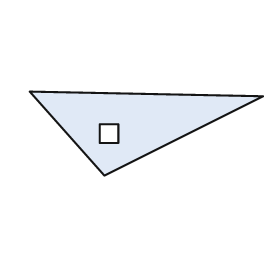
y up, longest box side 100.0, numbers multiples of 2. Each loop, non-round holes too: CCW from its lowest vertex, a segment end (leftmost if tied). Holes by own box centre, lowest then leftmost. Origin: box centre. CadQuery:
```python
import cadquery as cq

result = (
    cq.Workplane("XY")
    .moveTo(-18.0, -18.0)
    .lineTo(50.0, 16.0)
    .lineTo(-50.0, 18.0)
    .close()
    .moveTo(-20.0, -4.0)
    .lineTo(-12.0, -4.0)
    .lineTo(-12.0, 4.0)
    .lineTo(-20.0, 4.0)
    .close()
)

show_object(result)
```